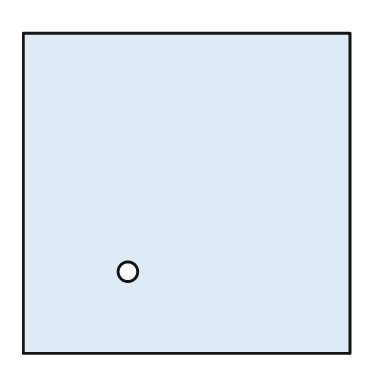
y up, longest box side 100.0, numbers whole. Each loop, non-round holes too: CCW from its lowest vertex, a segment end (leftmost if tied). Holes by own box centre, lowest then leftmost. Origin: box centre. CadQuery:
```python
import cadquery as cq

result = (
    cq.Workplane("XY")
    .moveTo(-50.0, -49.0)
    .lineTo(50.0, -49.0)
    .lineTo(50.0, 49.0)
    .lineTo(-50.0, 49.0)
    .close()
    .moveTo(-18.0, -24.0)
    .circle(3.0)
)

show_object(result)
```